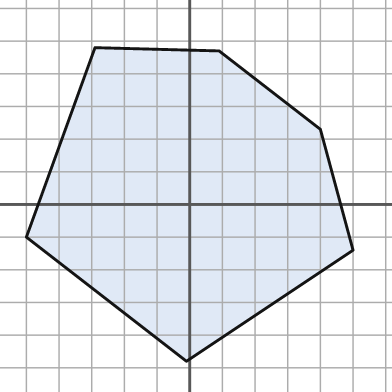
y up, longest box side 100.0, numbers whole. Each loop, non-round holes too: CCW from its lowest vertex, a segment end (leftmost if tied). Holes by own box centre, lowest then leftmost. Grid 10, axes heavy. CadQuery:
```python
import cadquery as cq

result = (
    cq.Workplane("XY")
    .moveTo(-1.0, -48.0)
    .lineTo(50.0, -14.0)
    .lineTo(40.0, 23.0)
    .lineTo(9.0, 47.0)
    .lineTo(-29.0, 48.0)
    .lineTo(-50.0, -10.0)
    .close()
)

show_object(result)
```